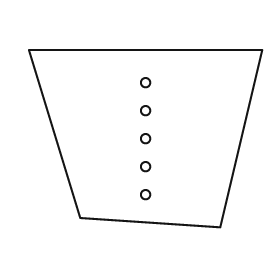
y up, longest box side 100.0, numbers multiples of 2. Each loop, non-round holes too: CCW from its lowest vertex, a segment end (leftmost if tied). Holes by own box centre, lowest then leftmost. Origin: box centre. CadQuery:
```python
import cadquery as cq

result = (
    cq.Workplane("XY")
    .moveTo(32.0, -38.0)
    .lineTo(50.0, 38.0)
    .lineTo(-50.0, 38.0)
    .lineTo(-28.0, -34.0)
    .close()
    .moveTo(0.0, -24.0)
    .circle(2.0)
    .moveTo(0.0, -12.0)
    .circle(2.0)
    .moveTo(0.0, 0.0)
    .circle(2.0)
    .moveTo(0.0, 12.0)
    .circle(2.0)
    .moveTo(0.0, 24.0)
    .circle(2.0)
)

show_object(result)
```